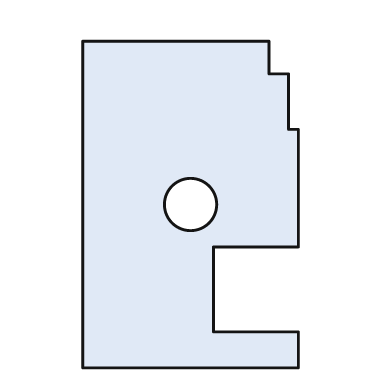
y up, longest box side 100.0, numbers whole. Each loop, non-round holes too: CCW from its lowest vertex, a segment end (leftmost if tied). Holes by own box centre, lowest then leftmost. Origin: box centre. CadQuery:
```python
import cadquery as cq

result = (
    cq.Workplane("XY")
    .moveTo(-33.0, -50.0)
    .lineTo(33.0, -50.0)
    .lineTo(33.0, -39.0)
    .lineTo(7.0, -39.0)
    .lineTo(7.0, -13.0)
    .lineTo(33.0, -13.0)
    .lineTo(33.0, 23.0)
    .lineTo(30.0, 23.0)
    .lineTo(30.0, 40.0)
    .lineTo(24.0, 40.0)
    .lineTo(24.0, 50.0)
    .lineTo(-33.0, 50.0)
    .close()
    .moveTo(0.0, 0.0)
    .circle(8.0)
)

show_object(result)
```